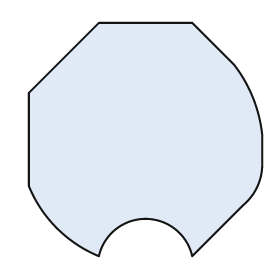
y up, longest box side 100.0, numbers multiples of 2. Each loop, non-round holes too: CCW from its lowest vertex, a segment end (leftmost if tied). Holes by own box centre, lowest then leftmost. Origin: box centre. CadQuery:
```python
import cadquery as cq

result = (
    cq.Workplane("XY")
    .moveTo(-20.0, -50.0)
    .threePointArc((0.0, -34.0), (20.0, -50.0))
    .lineTo(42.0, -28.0)
    .threePointArc((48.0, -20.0), (50.0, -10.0))
    .lineTo(50.0, 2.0)
    .threePointArc((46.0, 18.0), (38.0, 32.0))
    .lineTo(20.0, 50.0)
    .lineTo(-20.0, 50.0)
    .lineTo(-50.0, 20.0)
    .lineTo(-50.0, -20.0)
    .threePointArc((-38.0, -38.0), (-20.0, -50.0))
    .close()
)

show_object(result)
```